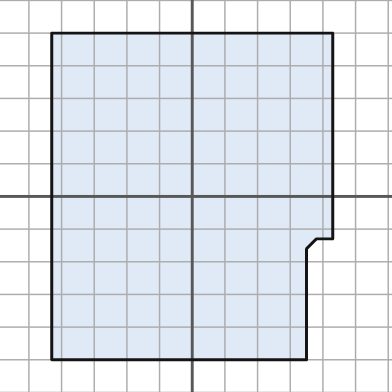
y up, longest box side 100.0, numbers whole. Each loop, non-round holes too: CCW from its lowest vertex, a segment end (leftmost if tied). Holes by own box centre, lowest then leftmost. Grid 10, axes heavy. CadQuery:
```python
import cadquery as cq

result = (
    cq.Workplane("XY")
    .moveTo(-43.0, -50.0)
    .lineTo(35.0, -50.0)
    .lineTo(35.0, -16.0)
    .lineTo(38.0, -13.0)
    .lineTo(43.0, -13.0)
    .lineTo(43.0, 50.0)
    .lineTo(-43.0, 50.0)
    .close()
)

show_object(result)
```